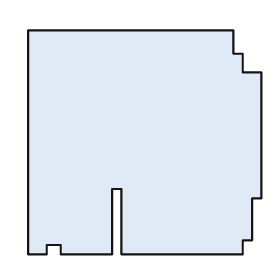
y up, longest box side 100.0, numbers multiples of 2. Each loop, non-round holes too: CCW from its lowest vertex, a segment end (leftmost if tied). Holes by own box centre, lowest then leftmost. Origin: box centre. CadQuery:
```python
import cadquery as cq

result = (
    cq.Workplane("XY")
    .moveTo(-50.0, -48.0)
    .lineTo(-42.0, -48.0)
    .lineTo(-42.0, -44.0)
    .lineTo(-36.0, -44.0)
    .lineTo(-36.0, -48.0)
    .lineTo(-14.0, -48.0)
    .lineTo(-14.0, -20.0)
    .lineTo(-10.0, -20.0)
    .lineTo(-10.0, -48.0)
    .lineTo(42.0, -48.0)
    .lineTo(42.0, -42.0)
    .lineTo(46.0, -42.0)
    .lineTo(46.0, -24.0)
    .lineTo(50.0, -24.0)
    .lineTo(50.0, 30.0)
    .lineTo(42.0, 30.0)
    .lineTo(42.0, 38.0)
    .lineTo(38.0, 38.0)
    .lineTo(38.0, 48.0)
    .lineTo(-50.0, 48.0)
    .close()
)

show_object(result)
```